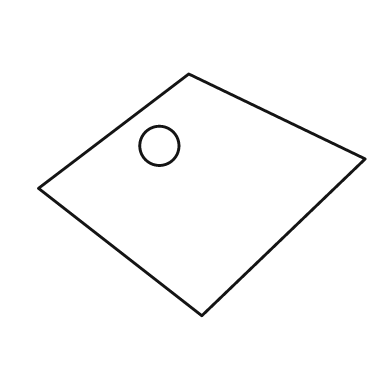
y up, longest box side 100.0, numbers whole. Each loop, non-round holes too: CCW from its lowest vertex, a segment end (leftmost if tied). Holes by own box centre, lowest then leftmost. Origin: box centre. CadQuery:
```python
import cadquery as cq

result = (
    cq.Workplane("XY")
    .moveTo(0.0, -37.0)
    .lineTo(50.0, 11.0)
    .lineTo(-4.0, 37.0)
    .lineTo(-50.0, 2.0)
    .close()
    .moveTo(-13.0, 15.0)
    .circle(6.0)
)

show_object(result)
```